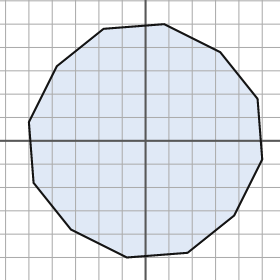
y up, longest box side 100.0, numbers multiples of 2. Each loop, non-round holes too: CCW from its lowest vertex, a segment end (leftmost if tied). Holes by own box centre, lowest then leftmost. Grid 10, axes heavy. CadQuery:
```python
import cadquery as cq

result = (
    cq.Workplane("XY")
    .moveTo(-8.0, -50.0)
    .lineTo(18.0, -48.0)
    .lineTo(38.0, -32.0)
    .lineTo(50.0, -8.0)
    .lineTo(48.0, 18.0)
    .lineTo(32.0, 38.0)
    .lineTo(8.0, 50.0)
    .lineTo(-18.0, 48.0)
    .lineTo(-38.0, 32.0)
    .lineTo(-50.0, 8.0)
    .lineTo(-48.0, -18.0)
    .lineTo(-32.0, -38.0)
    .close()
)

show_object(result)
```